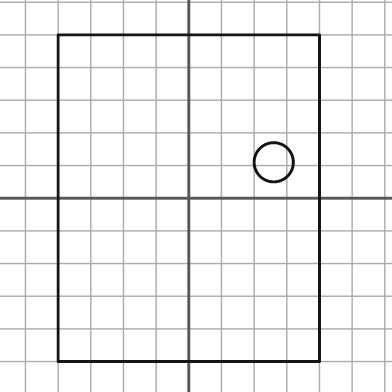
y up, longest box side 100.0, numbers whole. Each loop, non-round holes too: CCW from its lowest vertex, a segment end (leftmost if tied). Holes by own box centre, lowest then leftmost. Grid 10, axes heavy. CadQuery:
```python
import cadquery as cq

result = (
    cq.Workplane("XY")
    .moveTo(-40.0, -50.0)
    .lineTo(40.0, -50.0)
    .lineTo(40.0, 50.0)
    .lineTo(-40.0, 50.0)
    .close()
    .moveTo(26.0, 11.0)
    .circle(6.0)
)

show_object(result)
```